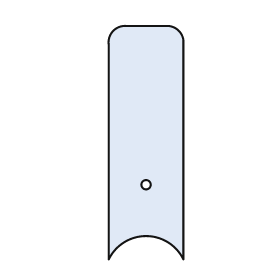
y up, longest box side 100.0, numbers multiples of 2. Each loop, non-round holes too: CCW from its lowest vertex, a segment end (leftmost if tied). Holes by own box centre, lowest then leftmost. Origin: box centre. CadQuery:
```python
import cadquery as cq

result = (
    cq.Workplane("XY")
    .moveTo(-16.0, -50.0)
    .threePointArc((0.0, -40.0), (16.0, -50.0))
    .lineTo(16.0, 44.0)
    .threePointArc((14.0, 48.0), (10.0, 50.0))
    .lineTo(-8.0, 50.0)
    .threePointArc((-14.0, 48.0), (-16.0, 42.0))
    .close()
    .moveTo(0.0, -18.0)
    .circle(2.0)
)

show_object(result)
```